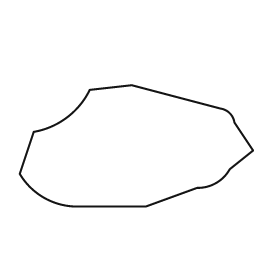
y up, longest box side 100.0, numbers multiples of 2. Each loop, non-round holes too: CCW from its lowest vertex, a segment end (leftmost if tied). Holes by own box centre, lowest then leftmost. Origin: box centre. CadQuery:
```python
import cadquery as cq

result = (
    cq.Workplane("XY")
    .moveTo(-26.0, -26.0)
    .lineTo(4.0, -26.0)
    .lineTo(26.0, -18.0)
    .threePointArc((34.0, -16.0), (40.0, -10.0))
    .lineTo(50.0, -2.0)
    .lineTo(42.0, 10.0)
    .threePointArc((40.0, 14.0), (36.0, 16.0))
    .lineTo(-2.0, 26.0)
    .lineTo(-20.0, 24.0)
    .threePointArc((-30.0, 12.0), (-44.0, 6.0))
    .lineTo(-50.0, -12.0)
    .threePointArc((-40.0, -22.0), (-26.0, -26.0))
    .close()
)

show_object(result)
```